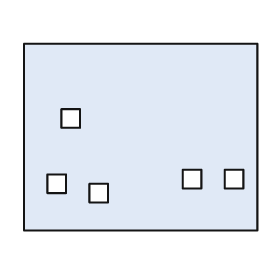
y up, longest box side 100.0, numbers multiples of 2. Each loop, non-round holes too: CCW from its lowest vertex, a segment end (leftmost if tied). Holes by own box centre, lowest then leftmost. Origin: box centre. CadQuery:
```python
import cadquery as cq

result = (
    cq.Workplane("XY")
    .moveTo(-50.0, -40.0)
    .lineTo(50.0, -40.0)
    .lineTo(50.0, 40.0)
    .lineTo(-50.0, 40.0)
    .close()
    .moveTo(-22.0, -28.0)
    .lineTo(-14.0, -28.0)
    .lineTo(-14.0, -20.0)
    .lineTo(-22.0, -20.0)
    .close()
    .moveTo(-40.0, -24.0)
    .lineTo(-32.0, -24.0)
    .lineTo(-32.0, -16.0)
    .lineTo(-40.0, -16.0)
    .close()
    .moveTo(18.0, -22.0)
    .lineTo(26.0, -22.0)
    .lineTo(26.0, -14.0)
    .lineTo(18.0, -14.0)
    .close()
    .moveTo(36.0, -22.0)
    .lineTo(44.0, -22.0)
    .lineTo(44.0, -14.0)
    .lineTo(36.0, -14.0)
    .close()
    .moveTo(-34.0, 4.0)
    .lineTo(-26.0, 4.0)
    .lineTo(-26.0, 12.0)
    .lineTo(-34.0, 12.0)
    .close()
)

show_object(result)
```